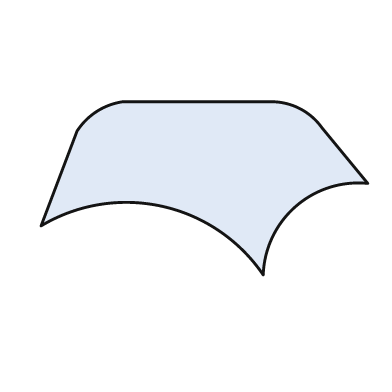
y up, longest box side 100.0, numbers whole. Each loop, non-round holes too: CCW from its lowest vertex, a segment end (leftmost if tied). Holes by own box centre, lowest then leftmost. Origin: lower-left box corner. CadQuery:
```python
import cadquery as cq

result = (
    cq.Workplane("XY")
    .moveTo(68.0, 0.0)
    .threePointArc((78.0, 21.0), (100.0, 28.0))
    .lineTo(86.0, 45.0)
    .threePointArc((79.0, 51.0), (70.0, 53.0))
    .lineTo(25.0, 53.0)
    .threePointArc((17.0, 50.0), (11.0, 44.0))
    .lineTo(0.0, 15.0)
    .threePointArc((37.0, 21.0), (68.0, 0.0))
    .close()
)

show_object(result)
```